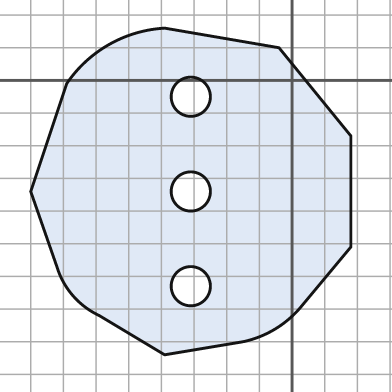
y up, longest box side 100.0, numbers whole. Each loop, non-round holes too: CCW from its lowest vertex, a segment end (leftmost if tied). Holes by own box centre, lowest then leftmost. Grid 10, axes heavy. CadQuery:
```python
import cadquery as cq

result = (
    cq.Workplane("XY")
    .moveTo(-39.0, -84.0)
    .lineTo(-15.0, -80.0)
    .threePointArc((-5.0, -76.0), (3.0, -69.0))
    .lineTo(18.0, -51.0)
    .lineTo(18.0, -17.0)
    .lineTo(-4.0, 10.0)
    .lineTo(-39.0, 16.0)
    .threePointArc((-56.0, 11.0), (-69.0, -1.0))
    .lineTo(-80.0, -34.0)
    .lineTo(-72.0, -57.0)
    .threePointArc((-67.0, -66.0), (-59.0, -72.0))
    .close()
    .moveTo(-31.0, -63.0)
    .circle(6.0)
    .moveTo(-31.0, -34.0)
    .circle(6.0)
    .moveTo(-31.0, -5.0)
    .circle(6.0)
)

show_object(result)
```